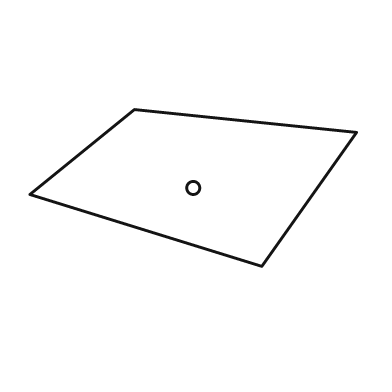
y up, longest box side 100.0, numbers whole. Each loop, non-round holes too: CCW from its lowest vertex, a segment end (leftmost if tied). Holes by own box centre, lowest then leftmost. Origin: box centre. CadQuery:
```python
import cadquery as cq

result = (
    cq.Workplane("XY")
    .moveTo(21.0, -24.0)
    .lineTo(50.0, 17.0)
    .lineTo(-18.0, 24.0)
    .lineTo(-50.0, -2.0)
    .close()
    .moveTo(0.0, 0.0)
    .circle(2.0)
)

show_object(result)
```